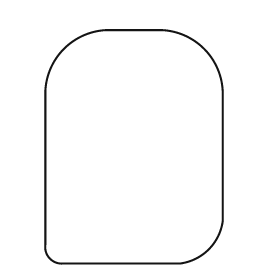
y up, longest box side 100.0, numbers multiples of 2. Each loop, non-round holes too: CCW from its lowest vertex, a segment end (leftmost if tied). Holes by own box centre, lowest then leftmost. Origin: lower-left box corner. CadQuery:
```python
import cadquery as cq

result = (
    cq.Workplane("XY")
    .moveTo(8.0, 0.0)
    .lineTo(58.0, 0.0)
    .threePointArc((70.0, 6.0), (76.0, 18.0))
    .lineTo(76.0, 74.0)
    .threePointArc((68.0, 92.0), (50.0, 100.0))
    .lineTo(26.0, 100.0)
    .threePointArc((8.0, 92.0), (0.0, 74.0))
    .lineTo(0.0, 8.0)
    .threePointArc((2.0, 2.0), (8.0, 0.0))
    .close()
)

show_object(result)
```